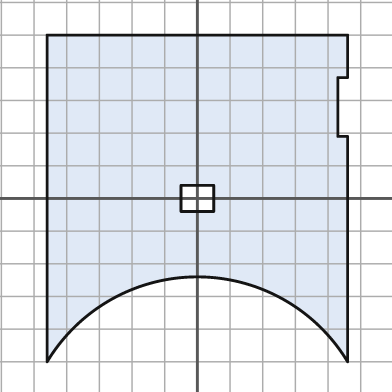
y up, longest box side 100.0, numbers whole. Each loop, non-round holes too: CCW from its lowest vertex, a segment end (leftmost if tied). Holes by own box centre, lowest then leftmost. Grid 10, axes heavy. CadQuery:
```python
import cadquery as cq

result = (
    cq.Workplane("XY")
    .moveTo(-46.0, -50.0)
    .threePointArc((0.0, -24.0), (46.0, -50.0))
    .lineTo(46.0, 19.0)
    .lineTo(43.0, 19.0)
    .lineTo(43.0, 37.0)
    .lineTo(46.0, 37.0)
    .lineTo(46.0, 50.0)
    .lineTo(-46.0, 50.0)
    .close()
    .moveTo(-5.0, -4.0)
    .lineTo(5.0, -4.0)
    .lineTo(5.0, 4.0)
    .lineTo(-5.0, 4.0)
    .close()
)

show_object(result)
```